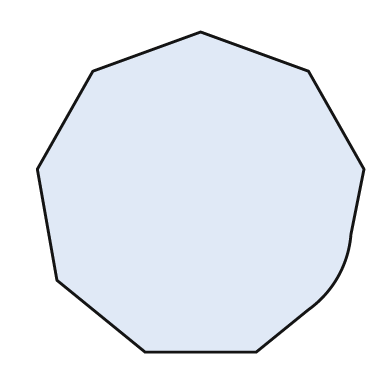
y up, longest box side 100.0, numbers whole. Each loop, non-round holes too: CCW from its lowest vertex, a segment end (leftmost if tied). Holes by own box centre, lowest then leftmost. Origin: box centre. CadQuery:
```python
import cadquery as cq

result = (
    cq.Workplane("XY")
    .moveTo(-17.0, -49.0)
    .lineTo(17.0, -49.0)
    .lineTo(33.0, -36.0)
    .threePointArc((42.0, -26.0), (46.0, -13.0))
    .lineTo(50.0, 7.0)
    .lineTo(33.0, 37.0)
    .lineTo(0.0, 49.0)
    .lineTo(-33.0, 37.0)
    .lineTo(-50.0, 7.0)
    .lineTo(-44.0, -27.0)
    .close()
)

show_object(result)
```